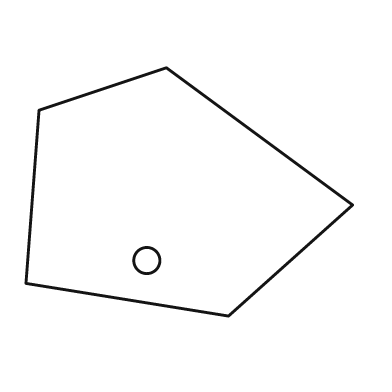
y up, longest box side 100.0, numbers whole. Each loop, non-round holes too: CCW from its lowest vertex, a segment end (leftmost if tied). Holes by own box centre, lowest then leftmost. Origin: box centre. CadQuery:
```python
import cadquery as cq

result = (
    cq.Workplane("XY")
    .moveTo(12.0, -38.0)
    .lineTo(50.0, -4.0)
    .lineTo(-7.0, 38.0)
    .lineTo(-46.0, 25.0)
    .lineTo(-50.0, -28.0)
    .close()
    .moveTo(-13.0, -21.0)
    .circle(4.0)
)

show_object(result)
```